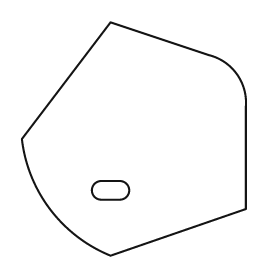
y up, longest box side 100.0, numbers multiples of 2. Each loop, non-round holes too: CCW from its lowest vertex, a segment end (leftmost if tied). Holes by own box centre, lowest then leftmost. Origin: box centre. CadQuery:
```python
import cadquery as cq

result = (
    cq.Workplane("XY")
    .moveTo(-10.0, -50.0)
    .lineTo(48.0, -30.0)
    .lineTo(48.0, 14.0)
    .threePointArc((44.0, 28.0), (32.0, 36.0))
    .lineTo(-10.0, 50.0)
    .lineTo(-48.0, 0.0)
    .threePointArc((-36.0, -30.0), (-10.0, -50.0))
    .close()
    .moveTo(-14.0, -26.0)
    .lineTo(-6.0, -26.0)
    .threePointArc((-2.0, -22.0), (-6.0, -18.0))
    .lineTo(-14.0, -18.0)
    .threePointArc((-18.0, -22.0), (-14.0, -26.0))
    .close()
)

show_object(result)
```